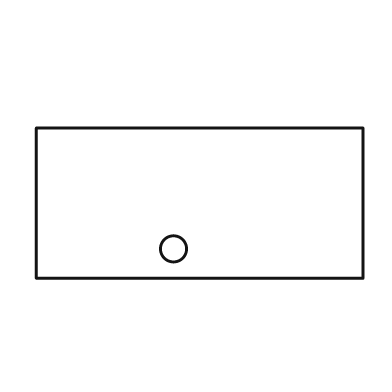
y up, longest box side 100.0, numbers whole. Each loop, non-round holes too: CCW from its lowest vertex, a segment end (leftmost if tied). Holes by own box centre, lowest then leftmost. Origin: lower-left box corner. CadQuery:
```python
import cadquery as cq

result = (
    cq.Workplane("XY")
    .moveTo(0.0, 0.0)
    .lineTo(100.0, 0.0)
    .lineTo(100.0, 46.0)
    .lineTo(0.0, 46.0)
    .close()
    .moveTo(42.0, 9.0)
    .circle(4.0)
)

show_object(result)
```